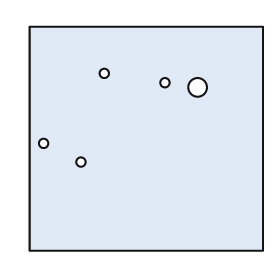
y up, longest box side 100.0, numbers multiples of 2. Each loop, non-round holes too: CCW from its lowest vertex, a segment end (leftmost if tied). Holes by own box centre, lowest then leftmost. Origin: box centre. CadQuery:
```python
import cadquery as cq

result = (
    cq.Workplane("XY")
    .moveTo(-50.0, -48.0)
    .lineTo(50.0, -48.0)
    .lineTo(50.0, 48.0)
    .lineTo(-50.0, 48.0)
    .close()
    .moveTo(-28.0, -10.0)
    .circle(2.0)
    .moveTo(-44.0, -2.0)
    .circle(2.0)
    .moveTo(22.0, 22.0)
    .circle(4.0)
    .moveTo(8.0, 24.0)
    .circle(2.0)
    .moveTo(-18.0, 28.0)
    .circle(2.0)
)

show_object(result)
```